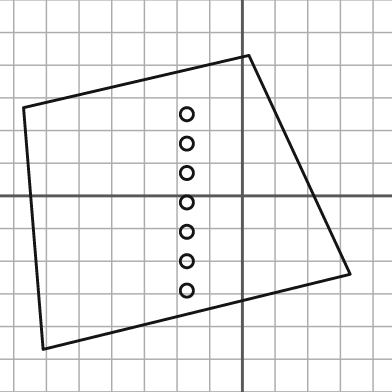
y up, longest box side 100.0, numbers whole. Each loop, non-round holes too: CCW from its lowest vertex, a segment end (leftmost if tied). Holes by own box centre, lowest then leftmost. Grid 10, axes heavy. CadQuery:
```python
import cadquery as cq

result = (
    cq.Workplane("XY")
    .moveTo(-61.0, -47.0)
    .lineTo(33.0, -24.0)
    .lineTo(2.0, 43.0)
    .lineTo(-67.0, 27.0)
    .close()
    .moveTo(-17.0, -29.0)
    .circle(2.0)
    .moveTo(-17.0, -20.0)
    .circle(2.0)
    .moveTo(-17.0, -11.0)
    .circle(2.0)
    .moveTo(-17.0, -2.0)
    .circle(2.0)
    .moveTo(-17.0, 7.0)
    .circle(2.0)
    .moveTo(-17.0, 16.0)
    .circle(2.0)
    .moveTo(-17.0, 25.0)
    .circle(2.0)
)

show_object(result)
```